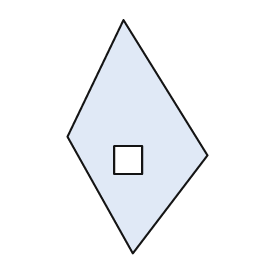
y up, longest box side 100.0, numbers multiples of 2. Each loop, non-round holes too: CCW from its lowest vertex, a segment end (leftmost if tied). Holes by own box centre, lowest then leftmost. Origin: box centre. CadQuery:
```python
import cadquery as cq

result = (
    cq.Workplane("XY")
    .moveTo(-2.0, -50.0)
    .lineTo(30.0, -8.0)
    .lineTo(-6.0, 50.0)
    .lineTo(-30.0, 0.0)
    .close()
    .moveTo(-10.0, -16.0)
    .lineTo(2.0, -16.0)
    .lineTo(2.0, -4.0)
    .lineTo(-10.0, -4.0)
    .close()
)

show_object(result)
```